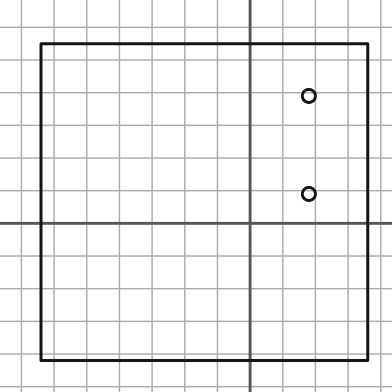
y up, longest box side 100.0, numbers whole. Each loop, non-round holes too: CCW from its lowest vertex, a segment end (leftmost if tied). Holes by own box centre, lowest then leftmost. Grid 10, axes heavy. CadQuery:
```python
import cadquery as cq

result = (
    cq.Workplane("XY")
    .moveTo(-64.0, -42.0)
    .lineTo(36.0, -42.0)
    .lineTo(36.0, 55.0)
    .lineTo(-64.0, 55.0)
    .close()
    .moveTo(18.0, 9.0)
    .circle(2.0)
    .moveTo(18.0, 39.0)
    .circle(2.0)
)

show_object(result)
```